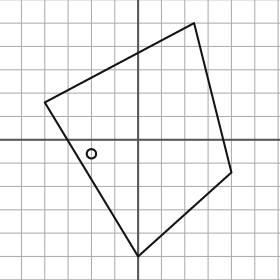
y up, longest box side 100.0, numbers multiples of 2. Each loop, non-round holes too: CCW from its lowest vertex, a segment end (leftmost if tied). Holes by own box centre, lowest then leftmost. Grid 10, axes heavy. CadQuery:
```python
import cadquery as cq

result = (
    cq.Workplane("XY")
    .moveTo(0.0, -50.0)
    .lineTo(40.0, -14.0)
    .lineTo(24.0, 50.0)
    .lineTo(-40.0, 16.0)
    .close()
    .moveTo(-20.0, -6.0)
    .circle(2.0)
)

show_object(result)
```